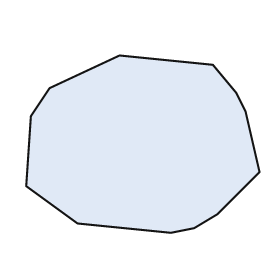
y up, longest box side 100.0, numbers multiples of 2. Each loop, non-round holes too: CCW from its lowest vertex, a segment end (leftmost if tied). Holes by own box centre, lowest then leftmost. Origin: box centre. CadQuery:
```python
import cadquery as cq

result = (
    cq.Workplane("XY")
    .moveTo(12.0, -38.0)
    .lineTo(22.0, -36.0)
    .lineTo(32.0, -30.0)
    .lineTo(50.0, -12.0)
    .lineTo(44.0, 14.0)
    .lineTo(40.0, 22.0)
    .lineTo(30.0, 34.0)
    .lineTo(-10.0, 38.0)
    .lineTo(-40.0, 24.0)
    .lineTo(-48.0, 12.0)
    .lineTo(-50.0, -18.0)
    .lineTo(-28.0, -34.0)
    .close()
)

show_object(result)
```